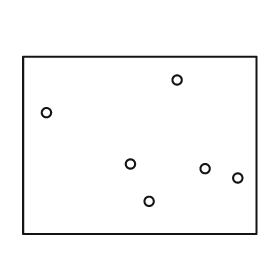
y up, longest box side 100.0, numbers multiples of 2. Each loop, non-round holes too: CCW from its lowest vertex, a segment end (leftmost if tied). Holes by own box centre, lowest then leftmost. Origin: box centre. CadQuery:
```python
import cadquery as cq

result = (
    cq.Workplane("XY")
    .moveTo(-50.0, -38.0)
    .lineTo(50.0, -38.0)
    .lineTo(50.0, 38.0)
    .lineTo(-50.0, 38.0)
    .close()
    .moveTo(4.0, -24.0)
    .circle(2.0)
    .moveTo(42.0, -14.0)
    .circle(2.0)
    .moveTo(28.0, -10.0)
    .circle(2.0)
    .moveTo(-4.0, -8.0)
    .circle(2.0)
    .moveTo(-40.0, 14.0)
    .circle(2.0)
    .moveTo(16.0, 28.0)
    .circle(2.0)
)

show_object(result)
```